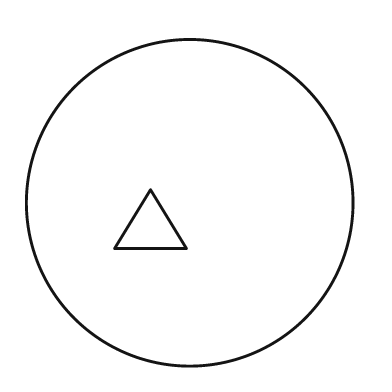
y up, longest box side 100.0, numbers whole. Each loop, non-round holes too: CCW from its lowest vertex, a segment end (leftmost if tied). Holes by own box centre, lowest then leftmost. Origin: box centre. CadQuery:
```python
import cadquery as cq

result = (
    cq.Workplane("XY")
    .moveTo(0.0, 0.0)
    .circle(50.0)
    .moveTo(-23.0, -14.0)
    .lineTo(-1.0, -14.0)
    .lineTo(-12.0, 4.0)
    .close()
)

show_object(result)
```